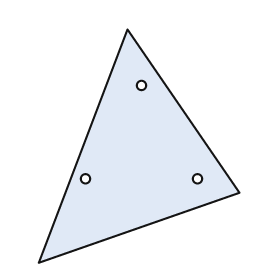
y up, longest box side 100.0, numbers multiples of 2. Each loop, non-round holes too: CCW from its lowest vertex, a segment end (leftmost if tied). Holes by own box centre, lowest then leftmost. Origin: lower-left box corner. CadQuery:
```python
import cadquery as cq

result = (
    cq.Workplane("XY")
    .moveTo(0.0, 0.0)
    .lineTo(86.0, 30.0)
    .lineTo(38.0, 100.0)
    .close()
    .moveTo(20.0, 36.0)
    .circle(2.0)
    .moveTo(68.0, 36.0)
    .circle(2.0)
    .moveTo(44.0, 76.0)
    .circle(2.0)
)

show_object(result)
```